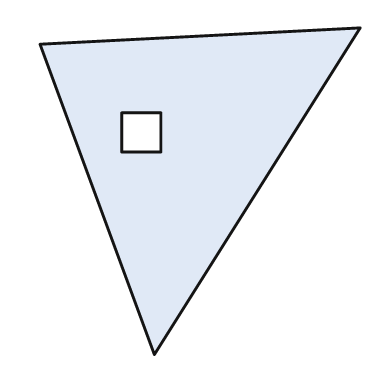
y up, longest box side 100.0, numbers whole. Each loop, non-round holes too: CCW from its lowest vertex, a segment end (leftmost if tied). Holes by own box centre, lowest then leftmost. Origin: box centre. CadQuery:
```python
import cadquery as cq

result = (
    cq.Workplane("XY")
    .moveTo(-14.0, -50.0)
    .lineTo(49.0, 50.0)
    .lineTo(-49.0, 45.0)
    .close()
    .moveTo(-24.0, 12.0)
    .lineTo(-12.0, 12.0)
    .lineTo(-12.0, 24.0)
    .lineTo(-24.0, 24.0)
    .close()
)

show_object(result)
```